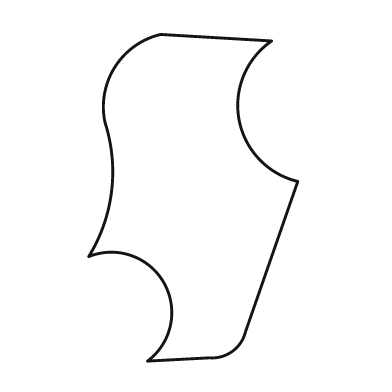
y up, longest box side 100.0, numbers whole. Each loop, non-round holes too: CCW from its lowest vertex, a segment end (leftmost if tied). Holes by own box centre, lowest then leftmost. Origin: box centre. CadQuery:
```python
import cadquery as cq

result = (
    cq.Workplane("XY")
    .moveTo(-14.0, -50.0)
    .lineTo(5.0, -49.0)
    .threePointArc((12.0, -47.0), (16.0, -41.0))
    .lineTo(32.0, 5.0)
    .threePointArc((14.0, 24.0), (24.0, 48.0))
    .lineTo(-10.0, 50.0)
    .threePointArc((-24.0, 40.0), (-27.0, 23.0))
    .threePointArc((-25.0, 2.0), (-32.0, -18.0))
    .threePointArc((-9.0, -26.0), (-14.0, -50.0))
    .close()
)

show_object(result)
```